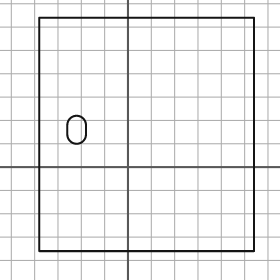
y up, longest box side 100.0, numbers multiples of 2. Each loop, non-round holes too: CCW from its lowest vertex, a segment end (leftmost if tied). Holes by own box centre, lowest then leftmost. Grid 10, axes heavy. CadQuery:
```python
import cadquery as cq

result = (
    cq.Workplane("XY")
    .moveTo(-38.0, -36.0)
    .lineTo(54.0, -36.0)
    .lineTo(54.0, 64.0)
    .lineTo(-38.0, 64.0)
    .close()
    .moveTo(-26.0, 14.0)
    .threePointArc((-22.0, 10.0), (-18.0, 14.0))
    .lineTo(-18.0, 18.0)
    .threePointArc((-22.0, 22.0), (-26.0, 18.0))
    .close()
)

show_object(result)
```